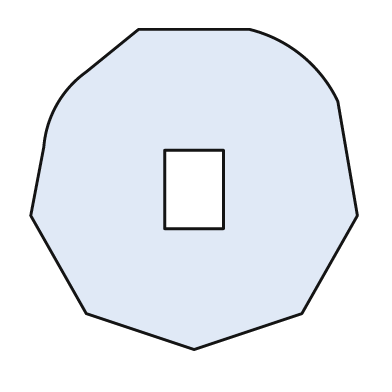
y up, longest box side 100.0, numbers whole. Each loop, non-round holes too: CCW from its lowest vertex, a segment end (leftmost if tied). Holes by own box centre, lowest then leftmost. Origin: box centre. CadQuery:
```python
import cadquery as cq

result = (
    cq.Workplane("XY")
    .moveTo(0.0, -49.0)
    .lineTo(33.0, -38.0)
    .lineTo(50.0, -8.0)
    .lineTo(44.0, 27.0)
    .threePointArc((33.0, 41.0), (17.0, 49.0))
    .lineTo(-17.0, 49.0)
    .lineTo(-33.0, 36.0)
    .threePointArc((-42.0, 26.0), (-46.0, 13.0))
    .lineTo(-50.0, -8.0)
    .lineTo(-33.0, -38.0)
    .close()
    .moveTo(-9.0, -12.0)
    .lineTo(9.0, -12.0)
    .lineTo(9.0, 12.0)
    .lineTo(-9.0, 12.0)
    .close()
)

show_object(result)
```